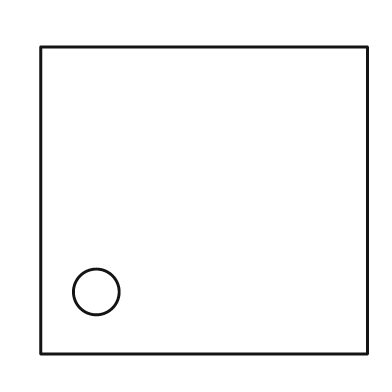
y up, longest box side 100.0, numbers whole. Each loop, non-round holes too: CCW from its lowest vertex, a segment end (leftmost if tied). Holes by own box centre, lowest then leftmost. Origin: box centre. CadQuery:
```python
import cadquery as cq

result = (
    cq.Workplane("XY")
    .moveTo(-50.0, -47.0)
    .lineTo(50.0, -47.0)
    .lineTo(50.0, 47.0)
    .lineTo(-50.0, 47.0)
    .close()
    .moveTo(-33.0, -28.0)
    .circle(7.0)
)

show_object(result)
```